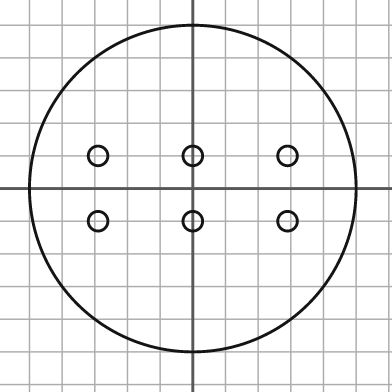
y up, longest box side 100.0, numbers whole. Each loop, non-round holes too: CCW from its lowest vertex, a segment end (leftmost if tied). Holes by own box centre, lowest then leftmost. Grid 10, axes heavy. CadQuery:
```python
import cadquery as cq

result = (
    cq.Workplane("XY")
    .moveTo(0.0, 0.0)
    .circle(50.0)
    .moveTo(-29.0, -10.0)
    .circle(3.0)
    .moveTo(0.0, -10.0)
    .circle(3.0)
    .moveTo(29.0, -10.0)
    .circle(3.0)
    .moveTo(-29.0, 10.0)
    .circle(3.0)
    .moveTo(0.0, 10.0)
    .circle(3.0)
    .moveTo(29.0, 10.0)
    .circle(3.0)
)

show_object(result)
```